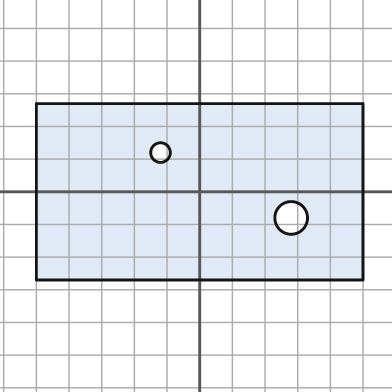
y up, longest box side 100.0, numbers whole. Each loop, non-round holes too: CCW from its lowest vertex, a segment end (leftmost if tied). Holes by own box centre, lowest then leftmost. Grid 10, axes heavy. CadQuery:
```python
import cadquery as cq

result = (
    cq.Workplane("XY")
    .moveTo(-50.0, -27.0)
    .lineTo(50.0, -27.0)
    .lineTo(50.0, 27.0)
    .lineTo(-50.0, 27.0)
    .close()
    .moveTo(28.0, -8.0)
    .circle(5.0)
    .moveTo(-12.0, 12.0)
    .circle(3.0)
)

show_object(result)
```